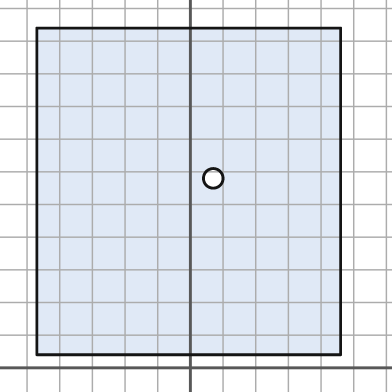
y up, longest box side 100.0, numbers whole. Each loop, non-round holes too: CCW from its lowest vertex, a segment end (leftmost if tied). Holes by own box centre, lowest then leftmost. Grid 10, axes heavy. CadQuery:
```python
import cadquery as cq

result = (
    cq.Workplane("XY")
    .moveTo(-47.0, 4.0)
    .lineTo(46.0, 4.0)
    .lineTo(46.0, 104.0)
    .lineTo(-47.0, 104.0)
    .close()
    .moveTo(7.0, 58.0)
    .circle(3.0)
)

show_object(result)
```